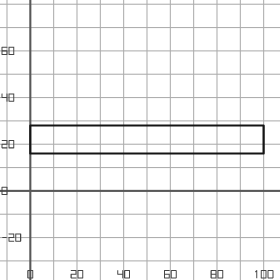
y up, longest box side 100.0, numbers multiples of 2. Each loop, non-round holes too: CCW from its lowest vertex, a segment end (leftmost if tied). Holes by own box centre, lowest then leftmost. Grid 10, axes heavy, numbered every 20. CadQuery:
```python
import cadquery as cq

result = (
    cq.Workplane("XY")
    .moveTo(0.0, 16.0)
    .lineTo(100.0, 16.0)
    .lineTo(100.0, 28.0)
    .lineTo(0.0, 28.0)
    .close()
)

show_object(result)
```